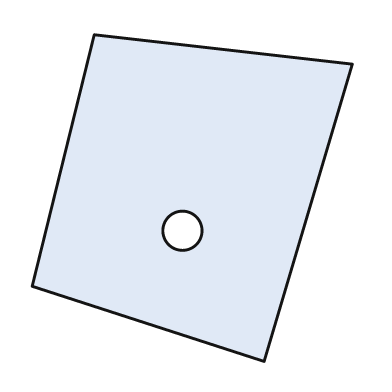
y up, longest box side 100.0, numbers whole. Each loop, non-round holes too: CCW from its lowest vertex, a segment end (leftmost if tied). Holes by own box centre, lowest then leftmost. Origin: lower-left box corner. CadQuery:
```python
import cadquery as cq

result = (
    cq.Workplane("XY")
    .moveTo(71.0, 0.0)
    .lineTo(98.0, 91.0)
    .lineTo(19.0, 100.0)
    .lineTo(0.0, 23.0)
    .close()
    .moveTo(46.0, 40.0)
    .circle(6.0)
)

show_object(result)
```